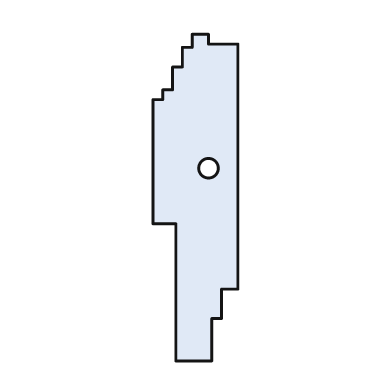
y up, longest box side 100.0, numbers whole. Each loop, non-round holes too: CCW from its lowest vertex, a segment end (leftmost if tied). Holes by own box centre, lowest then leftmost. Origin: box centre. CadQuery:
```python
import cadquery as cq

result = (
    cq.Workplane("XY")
    .moveTo(-6.0, -50.0)
    .lineTo(5.0, -50.0)
    .lineTo(5.0, -37.0)
    .lineTo(8.0, -37.0)
    .lineTo(8.0, -28.0)
    .lineTo(13.0, -28.0)
    .lineTo(13.0, 47.0)
    .lineTo(4.0, 47.0)
    .lineTo(4.0, 50.0)
    .lineTo(-1.0, 50.0)
    .lineTo(-1.0, 46.0)
    .lineTo(-4.0, 46.0)
    .lineTo(-4.0, 40.0)
    .lineTo(-7.0, 40.0)
    .lineTo(-7.0, 33.0)
    .lineTo(-10.0, 33.0)
    .lineTo(-10.0, 30.0)
    .lineTo(-13.0, 30.0)
    .lineTo(-13.0, -8.0)
    .lineTo(-6.0, -8.0)
    .close()
    .moveTo(4.0, 9.0)
    .circle(3.0)
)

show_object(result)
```